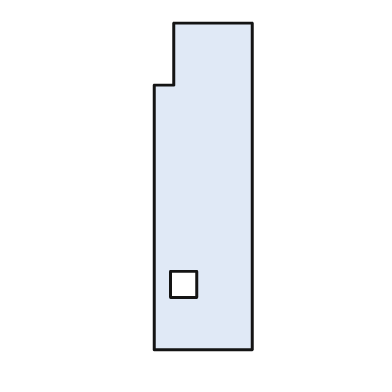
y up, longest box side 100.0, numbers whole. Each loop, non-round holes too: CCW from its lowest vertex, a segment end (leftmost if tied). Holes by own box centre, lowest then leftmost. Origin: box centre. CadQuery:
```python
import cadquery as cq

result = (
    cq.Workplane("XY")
    .moveTo(-15.0, -50.0)
    .lineTo(15.0, -50.0)
    .lineTo(15.0, 50.0)
    .lineTo(-9.0, 50.0)
    .lineTo(-9.0, 31.0)
    .lineTo(-15.0, 31.0)
    .close()
    .moveTo(-10.0, -34.0)
    .lineTo(-2.0, -34.0)
    .lineTo(-2.0, -26.0)
    .lineTo(-10.0, -26.0)
    .close()
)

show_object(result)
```